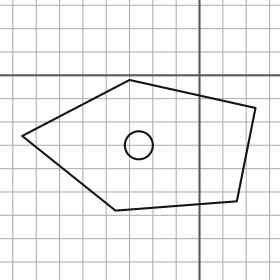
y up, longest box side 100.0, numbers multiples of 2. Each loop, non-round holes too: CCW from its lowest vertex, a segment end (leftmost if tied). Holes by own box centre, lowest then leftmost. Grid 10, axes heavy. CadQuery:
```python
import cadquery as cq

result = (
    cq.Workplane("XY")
    .moveTo(-36.0, -58.0)
    .lineTo(16.0, -54.0)
    .lineTo(24.0, -14.0)
    .lineTo(-30.0, -2.0)
    .lineTo(-76.0, -26.0)
    .close()
    .moveTo(-26.0, -30.0)
    .circle(6.0)
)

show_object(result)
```